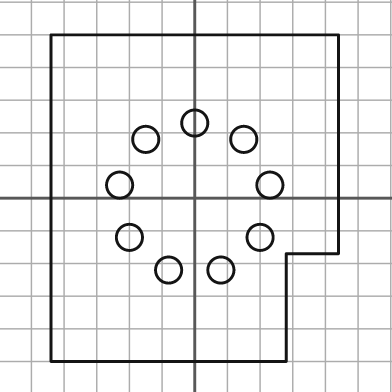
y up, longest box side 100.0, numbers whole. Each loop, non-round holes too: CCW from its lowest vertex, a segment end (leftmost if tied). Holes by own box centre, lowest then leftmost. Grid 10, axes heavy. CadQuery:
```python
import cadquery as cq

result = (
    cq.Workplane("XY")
    .moveTo(-44.0, -50.0)
    .lineTo(28.0, -50.0)
    .lineTo(28.0, -17.0)
    .lineTo(44.0, -17.0)
    .lineTo(44.0, 50.0)
    .lineTo(-44.0, 50.0)
    .close()
    .moveTo(-8.0, -22.0)
    .circle(4.0)
    .moveTo(8.0, -22.0)
    .circle(4.0)
    .moveTo(-20.0, -12.0)
    .circle(4.0)
    .moveTo(20.0, -12.0)
    .circle(4.0)
    .moveTo(-23.0, 4.0)
    .circle(4.0)
    .moveTo(23.0, 4.0)
    .circle(4.0)
    .moveTo(-15.0, 18.0)
    .circle(4.0)
    .moveTo(15.0, 18.0)
    .circle(4.0)
    .moveTo(0.0, 23.0)
    .circle(4.0)
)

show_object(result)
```